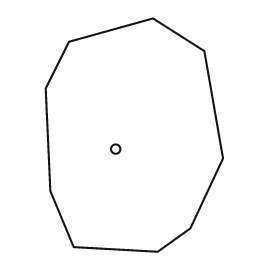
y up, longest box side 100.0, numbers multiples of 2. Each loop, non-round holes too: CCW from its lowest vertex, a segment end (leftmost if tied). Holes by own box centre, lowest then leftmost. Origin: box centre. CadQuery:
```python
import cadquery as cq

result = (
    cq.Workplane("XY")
    .moveTo(10.0, -50.0)
    .lineTo(24.0, -40.0)
    .lineTo(38.0, -10.0)
    .lineTo(30.0, 36.0)
    .lineTo(8.0, 50.0)
    .lineTo(-28.0, 40.0)
    .lineTo(-38.0, 20.0)
    .lineTo(-36.0, -24.0)
    .lineTo(-26.0, -48.0)
    .close()
    .moveTo(-8.0, -6.0)
    .circle(2.0)
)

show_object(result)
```